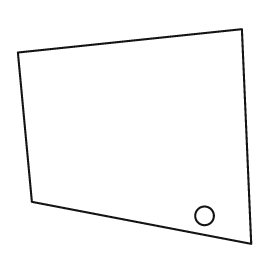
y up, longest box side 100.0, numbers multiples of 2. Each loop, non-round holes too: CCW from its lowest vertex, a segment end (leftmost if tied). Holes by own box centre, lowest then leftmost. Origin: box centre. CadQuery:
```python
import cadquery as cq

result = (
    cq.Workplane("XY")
    .moveTo(50.0, -46.0)
    .lineTo(46.0, 46.0)
    .lineTo(-50.0, 36.0)
    .lineTo(-44.0, -28.0)
    .close()
    .moveTo(30.0, -34.0)
    .circle(4.0)
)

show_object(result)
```